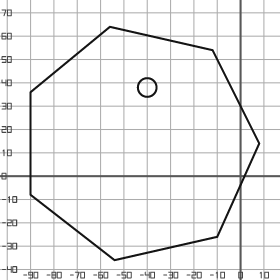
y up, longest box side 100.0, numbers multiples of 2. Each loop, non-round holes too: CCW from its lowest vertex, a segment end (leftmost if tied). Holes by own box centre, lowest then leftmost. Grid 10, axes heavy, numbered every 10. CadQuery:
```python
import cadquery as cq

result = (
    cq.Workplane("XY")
    .moveTo(-54.0, -36.0)
    .lineTo(-10.0, -26.0)
    .lineTo(8.0, 14.0)
    .lineTo(-12.0, 54.0)
    .lineTo(-56.0, 64.0)
    .lineTo(-90.0, 36.0)
    .lineTo(-90.0, -8.0)
    .close()
    .moveTo(-40.0, 38.0)
    .circle(4.0)
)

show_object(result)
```